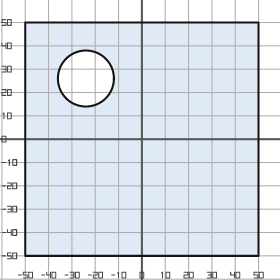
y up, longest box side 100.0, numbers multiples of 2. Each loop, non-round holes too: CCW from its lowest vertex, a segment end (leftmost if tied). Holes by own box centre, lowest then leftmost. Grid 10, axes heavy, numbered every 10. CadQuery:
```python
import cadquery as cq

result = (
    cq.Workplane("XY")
    .moveTo(-50.0, -50.0)
    .lineTo(50.0, -50.0)
    .lineTo(50.0, 50.0)
    .lineTo(-50.0, 50.0)
    .close()
    .moveTo(-24.0, 26.0)
    .circle(12.0)
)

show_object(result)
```